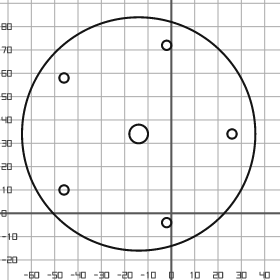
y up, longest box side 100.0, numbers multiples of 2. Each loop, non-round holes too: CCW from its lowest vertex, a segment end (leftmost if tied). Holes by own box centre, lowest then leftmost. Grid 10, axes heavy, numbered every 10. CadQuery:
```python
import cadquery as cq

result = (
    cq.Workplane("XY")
    .moveTo(-14.0, 34.0)
    .circle(50.0)
    .moveTo(-2.0, -4.0)
    .circle(2.0)
    .moveTo(-46.0, 10.0)
    .circle(2.0)
    .moveTo(-14.0, 34.0)
    .circle(4.0)
    .moveTo(26.0, 34.0)
    .circle(2.0)
    .moveTo(-46.0, 58.0)
    .circle(2.0)
    .moveTo(-2.0, 72.0)
    .circle(2.0)
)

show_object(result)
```